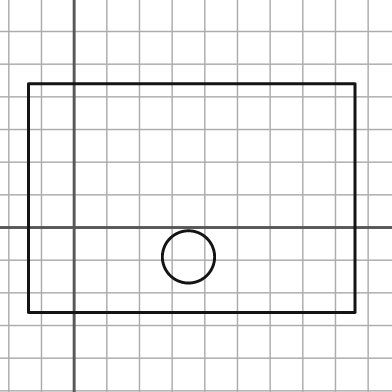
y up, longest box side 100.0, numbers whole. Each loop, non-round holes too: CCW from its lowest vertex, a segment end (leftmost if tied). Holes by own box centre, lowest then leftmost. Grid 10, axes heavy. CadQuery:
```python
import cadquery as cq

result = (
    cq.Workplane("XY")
    .moveTo(-14.0, -26.0)
    .lineTo(86.0, -26.0)
    .lineTo(86.0, 44.0)
    .lineTo(-14.0, 44.0)
    .close()
    .moveTo(35.0, -9.0)
    .circle(8.0)
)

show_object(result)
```